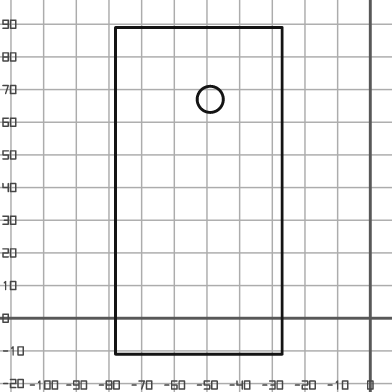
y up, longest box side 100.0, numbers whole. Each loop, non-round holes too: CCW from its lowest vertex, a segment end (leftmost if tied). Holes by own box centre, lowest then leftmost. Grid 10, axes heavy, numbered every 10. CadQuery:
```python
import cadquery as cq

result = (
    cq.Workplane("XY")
    .moveTo(-78.0, -11.0)
    .lineTo(-27.0, -11.0)
    .lineTo(-27.0, 89.0)
    .lineTo(-78.0, 89.0)
    .close()
    .moveTo(-49.0, 67.0)
    .circle(4.0)
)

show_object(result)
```